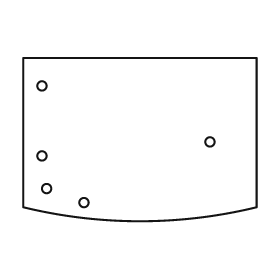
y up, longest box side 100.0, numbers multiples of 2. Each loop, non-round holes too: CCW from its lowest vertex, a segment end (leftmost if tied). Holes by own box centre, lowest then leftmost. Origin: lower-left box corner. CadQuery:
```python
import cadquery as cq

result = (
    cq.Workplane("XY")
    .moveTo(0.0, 6.0)
    .threePointArc((50.0, 0.0), (100.0, 6.0))
    .lineTo(100.0, 70.0)
    .lineTo(0.0, 70.0)
    .close()
    .moveTo(26.0, 8.0)
    .circle(2.0)
    .moveTo(10.0, 14.0)
    .circle(2.0)
    .moveTo(8.0, 28.0)
    .circle(2.0)
    .moveTo(80.0, 34.0)
    .circle(2.0)
    .moveTo(8.0, 58.0)
    .circle(2.0)
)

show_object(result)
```